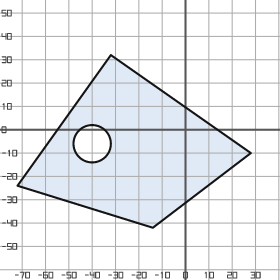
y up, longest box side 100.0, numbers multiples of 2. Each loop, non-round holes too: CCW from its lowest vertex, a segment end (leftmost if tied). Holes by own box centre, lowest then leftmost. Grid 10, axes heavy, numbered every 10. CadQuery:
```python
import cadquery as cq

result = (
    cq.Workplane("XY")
    .moveTo(-14.0, -42.0)
    .lineTo(28.0, -10.0)
    .lineTo(-32.0, 32.0)
    .lineTo(-72.0, -24.0)
    .close()
    .moveTo(-40.0, -6.0)
    .circle(8.0)
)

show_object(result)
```